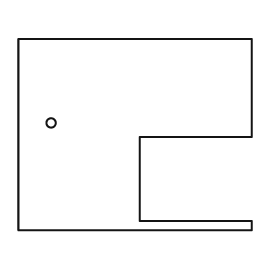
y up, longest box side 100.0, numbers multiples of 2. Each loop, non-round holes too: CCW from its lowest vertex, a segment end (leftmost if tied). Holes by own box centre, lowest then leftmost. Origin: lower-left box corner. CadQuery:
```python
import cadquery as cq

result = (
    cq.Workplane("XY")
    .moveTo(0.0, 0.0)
    .lineTo(100.0, 0.0)
    .lineTo(100.0, 4.0)
    .lineTo(52.0, 4.0)
    .lineTo(52.0, 40.0)
    .lineTo(100.0, 40.0)
    .lineTo(100.0, 82.0)
    .lineTo(0.0, 82.0)
    .close()
    .moveTo(14.0, 46.0)
    .circle(2.0)
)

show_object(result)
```